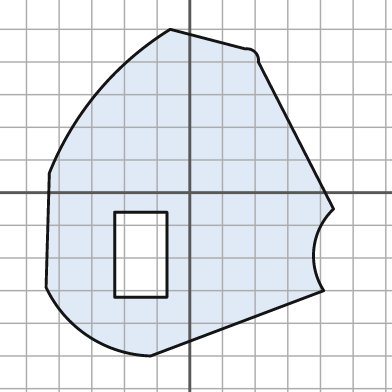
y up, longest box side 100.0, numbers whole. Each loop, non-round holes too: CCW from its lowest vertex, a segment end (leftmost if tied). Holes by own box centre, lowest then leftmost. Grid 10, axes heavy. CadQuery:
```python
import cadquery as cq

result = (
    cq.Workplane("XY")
    .moveTo(-12.0, -50.0)
    .lineTo(41.0, -30.0)
    .threePointArc((38.0, -17.0), (44.0, -5.0))
    .lineTo(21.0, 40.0)
    .threePointArc((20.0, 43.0), (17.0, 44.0))
    .lineTo(-6.0, 50.0)
    .threePointArc((-28.0, 31.0), (-43.0, 6.0))
    .lineTo(-44.0, -29.0)
    .threePointArc((-31.0, -44.0), (-12.0, -50.0))
    .close()
    .moveTo(-23.0, -32.0)
    .lineTo(-7.0, -32.0)
    .lineTo(-7.0, -6.0)
    .lineTo(-23.0, -6.0)
    .close()
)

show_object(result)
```